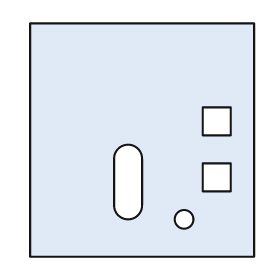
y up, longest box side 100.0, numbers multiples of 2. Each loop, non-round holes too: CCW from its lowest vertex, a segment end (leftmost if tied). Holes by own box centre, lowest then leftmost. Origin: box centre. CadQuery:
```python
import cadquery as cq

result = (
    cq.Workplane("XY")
    .moveTo(-48.0, -50.0)
    .lineTo(48.0, -50.0)
    .lineTo(48.0, 50.0)
    .lineTo(-48.0, 50.0)
    .close()
    .moveTo(18.0, -34.0)
    .circle(4.0)
    .moveTo(-12.0, -28.0)
    .threePointArc((-6.0, -34.0), (0.0, -28.0))
    .lineTo(0.0, -8.0)
    .threePointArc((-6.0, -2.0), (-12.0, -8.0))
    .close()
    .moveTo(26.0, -22.0)
    .lineTo(38.0, -22.0)
    .lineTo(38.0, -10.0)
    .lineTo(26.0, -10.0)
    .close()
    .moveTo(26.0, 2.0)
    .lineTo(38.0, 2.0)
    .lineTo(38.0, 14.0)
    .lineTo(26.0, 14.0)
    .close()
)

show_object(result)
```